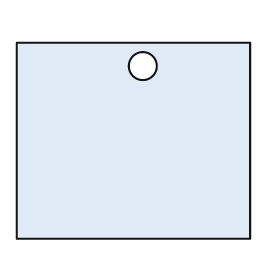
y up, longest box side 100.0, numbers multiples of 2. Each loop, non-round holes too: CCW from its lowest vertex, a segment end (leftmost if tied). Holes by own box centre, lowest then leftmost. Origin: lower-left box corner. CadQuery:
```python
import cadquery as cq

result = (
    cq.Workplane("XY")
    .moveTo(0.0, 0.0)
    .lineTo(100.0, 0.0)
    .lineTo(100.0, 84.0)
    .lineTo(0.0, 84.0)
    .close()
    .moveTo(54.0, 74.0)
    .circle(6.0)
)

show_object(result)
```